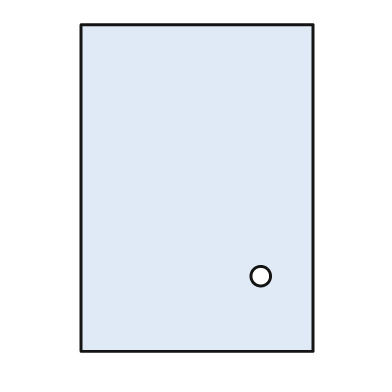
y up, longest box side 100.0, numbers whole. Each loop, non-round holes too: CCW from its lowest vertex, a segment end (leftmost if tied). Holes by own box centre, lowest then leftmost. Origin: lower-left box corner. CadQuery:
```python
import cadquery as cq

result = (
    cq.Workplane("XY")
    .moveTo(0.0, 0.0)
    .lineTo(71.0, 0.0)
    .lineTo(71.0, 100.0)
    .lineTo(0.0, 100.0)
    .close()
    .moveTo(55.0, 23.0)
    .circle(3.0)
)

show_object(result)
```